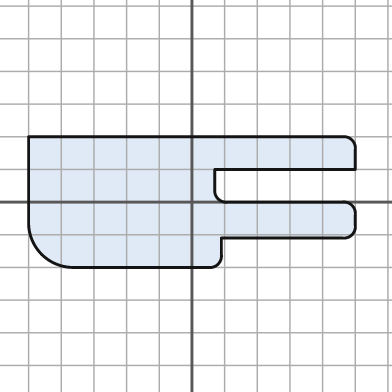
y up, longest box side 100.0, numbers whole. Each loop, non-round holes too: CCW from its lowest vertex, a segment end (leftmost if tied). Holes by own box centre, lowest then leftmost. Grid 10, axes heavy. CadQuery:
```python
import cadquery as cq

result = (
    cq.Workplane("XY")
    .moveTo(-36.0, -20.0)
    .lineTo(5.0, -20.0)
    .threePointArc((8.0, -19.0), (9.0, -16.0))
    .lineTo(9.0, -11.0)
    .lineTo(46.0, -11.0)
    .threePointArc((49.0, -10.0), (50.0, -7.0))
    .lineTo(50.0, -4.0)
    .threePointArc((49.0, -1.0), (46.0, 0.0))
    .lineTo(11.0, 0.0)
    .threePointArc((8.0, 1.0), (7.0, 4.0))
    .lineTo(7.0, 10.0)
    .lineTo(50.0, 10.0)
    .lineTo(50.0, 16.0)
    .threePointArc((49.0, 19.0), (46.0, 20.0))
    .lineTo(-50.0, 20.0)
    .lineTo(-50.0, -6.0)
    .threePointArc((-46.0, -16.0), (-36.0, -20.0))
    .close()
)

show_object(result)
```